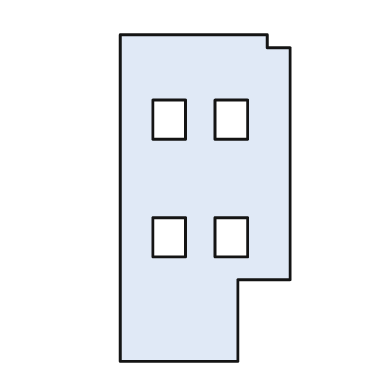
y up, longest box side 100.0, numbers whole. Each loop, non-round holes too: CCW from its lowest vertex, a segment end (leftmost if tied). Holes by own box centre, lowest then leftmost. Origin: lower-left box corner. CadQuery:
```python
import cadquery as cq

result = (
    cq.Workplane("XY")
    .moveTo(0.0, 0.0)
    .lineTo(36.0, 0.0)
    .lineTo(36.0, 25.0)
    .lineTo(52.0, 25.0)
    .lineTo(52.0, 96.0)
    .lineTo(45.0, 96.0)
    .lineTo(45.0, 100.0)
    .lineTo(0.0, 100.0)
    .close()
    .moveTo(10.0, 32.0)
    .lineTo(20.0, 32.0)
    .lineTo(20.0, 44.0)
    .lineTo(10.0, 44.0)
    .close()
    .moveTo(29.0, 32.0)
    .lineTo(39.0, 32.0)
    .lineTo(39.0, 44.0)
    .lineTo(29.0, 44.0)
    .close()
    .moveTo(10.0, 68.0)
    .lineTo(20.0, 68.0)
    .lineTo(20.0, 80.0)
    .lineTo(10.0, 80.0)
    .close()
    .moveTo(29.0, 68.0)
    .lineTo(39.0, 68.0)
    .lineTo(39.0, 80.0)
    .lineTo(29.0, 80.0)
    .close()
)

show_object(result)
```